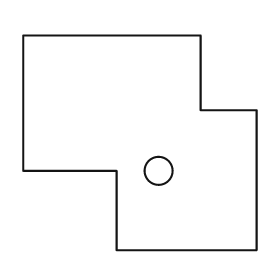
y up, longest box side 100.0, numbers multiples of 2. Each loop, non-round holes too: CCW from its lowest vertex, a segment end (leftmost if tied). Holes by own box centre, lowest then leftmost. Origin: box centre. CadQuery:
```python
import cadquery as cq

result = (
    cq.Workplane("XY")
    .moveTo(-10.0, -46.0)
    .lineTo(50.0, -46.0)
    .lineTo(50.0, 14.0)
    .lineTo(26.0, 14.0)
    .lineTo(26.0, 46.0)
    .lineTo(-50.0, 46.0)
    .lineTo(-50.0, -12.0)
    .lineTo(-10.0, -12.0)
    .close()
    .moveTo(8.0, -12.0)
    .circle(6.0)
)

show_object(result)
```